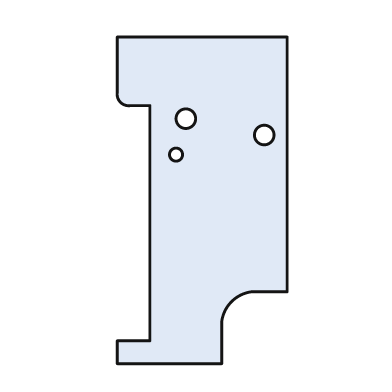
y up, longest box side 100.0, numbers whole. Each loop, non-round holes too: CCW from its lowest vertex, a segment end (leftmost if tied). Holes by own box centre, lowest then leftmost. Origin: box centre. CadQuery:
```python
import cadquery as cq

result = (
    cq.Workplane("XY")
    .moveTo(-26.0, -50.0)
    .lineTo(6.0, -50.0)
    .lineTo(6.0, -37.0)
    .threePointArc((9.0, -31.0), (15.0, -28.0))
    .lineTo(26.0, -28.0)
    .lineTo(26.0, 50.0)
    .lineTo(-26.0, 50.0)
    .lineTo(-26.0, 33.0)
    .threePointArc((-25.0, 30.0), (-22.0, 29.0))
    .lineTo(-16.0, 29.0)
    .lineTo(-16.0, -43.0)
    .lineTo(-26.0, -43.0)
    .close()
    .moveTo(-8.0, 14.0)
    .circle(2.0)
    .moveTo(19.0, 20.0)
    .circle(3.0)
    .moveTo(-5.0, 25.0)
    .circle(3.0)
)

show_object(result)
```